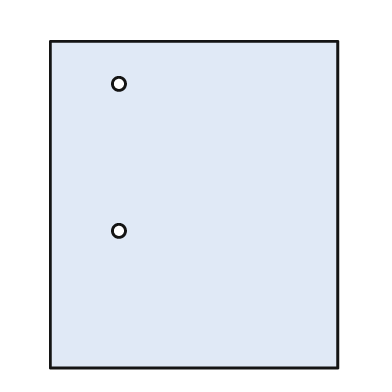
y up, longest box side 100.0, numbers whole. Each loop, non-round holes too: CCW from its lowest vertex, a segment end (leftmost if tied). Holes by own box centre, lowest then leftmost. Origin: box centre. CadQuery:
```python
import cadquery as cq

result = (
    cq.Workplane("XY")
    .moveTo(-44.0, -50.0)
    .lineTo(44.0, -50.0)
    .lineTo(44.0, 50.0)
    .lineTo(-44.0, 50.0)
    .close()
    .moveTo(-23.0, -8.0)
    .circle(2.0)
    .moveTo(-23.0, 37.0)
    .circle(2.0)
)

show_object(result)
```